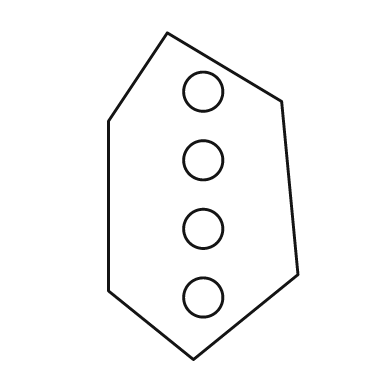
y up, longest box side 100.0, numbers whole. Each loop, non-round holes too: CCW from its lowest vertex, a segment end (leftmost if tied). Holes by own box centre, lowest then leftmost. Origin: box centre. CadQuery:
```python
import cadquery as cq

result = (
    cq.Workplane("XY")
    .moveTo(-3.0, -50.0)
    .lineTo(29.0, -24.0)
    .lineTo(24.0, 29.0)
    .lineTo(-11.0, 50.0)
    .lineTo(-29.0, 23.0)
    .lineTo(-29.0, -29.0)
    .close()
    .moveTo(0.0, -31.0)
    .circle(6.0)
    .moveTo(0.0, -10.0)
    .circle(6.0)
    .moveTo(0.0, 11.0)
    .circle(6.0)
    .moveTo(0.0, 32.0)
    .circle(6.0)
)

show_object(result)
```